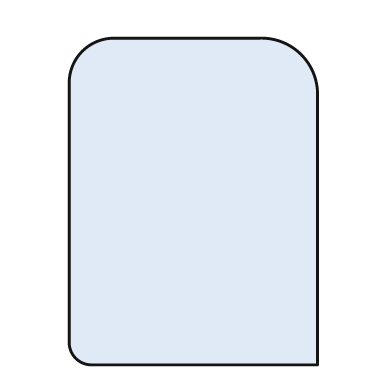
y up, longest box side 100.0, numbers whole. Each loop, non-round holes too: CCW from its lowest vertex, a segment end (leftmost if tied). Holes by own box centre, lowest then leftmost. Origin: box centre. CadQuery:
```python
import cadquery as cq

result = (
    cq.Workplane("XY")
    .moveTo(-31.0, -50.0)
    .lineTo(38.0, -50.0)
    .lineTo(38.0, 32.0)
    .threePointArc((33.0, 45.0), (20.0, 50.0))
    .lineTo(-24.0, 50.0)
    .threePointArc((-34.0, 46.0), (-38.0, 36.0))
    .lineTo(-38.0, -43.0)
    .threePointArc((-36.0, -48.0), (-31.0, -50.0))
    .close()
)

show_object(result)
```